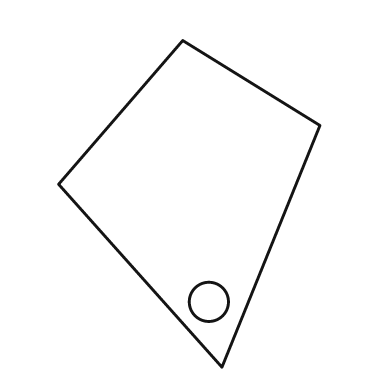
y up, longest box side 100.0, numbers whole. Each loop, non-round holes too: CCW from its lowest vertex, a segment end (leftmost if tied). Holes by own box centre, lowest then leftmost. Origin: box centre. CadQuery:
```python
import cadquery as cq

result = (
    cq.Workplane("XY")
    .moveTo(10.0, -50.0)
    .lineTo(40.0, 24.0)
    .lineTo(-2.0, 50.0)
    .lineTo(-40.0, 6.0)
    .close()
    .moveTo(6.0, -30.0)
    .circle(6.0)
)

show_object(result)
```